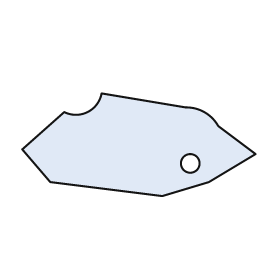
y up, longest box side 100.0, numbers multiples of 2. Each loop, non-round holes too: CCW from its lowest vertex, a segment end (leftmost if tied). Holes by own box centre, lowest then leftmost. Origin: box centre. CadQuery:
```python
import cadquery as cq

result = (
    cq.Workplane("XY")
    .moveTo(10.0, -22.0)
    .lineTo(30.0, -16.0)
    .lineTo(50.0, -4.0)
    .lineTo(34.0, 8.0)
    .threePointArc((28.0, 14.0), (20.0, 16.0))
    .lineTo(-16.0, 22.0)
    .threePointArc((-22.0, 14.0), (-32.0, 14.0))
    .lineTo(-50.0, -2.0)
    .lineTo(-38.0, -16.0)
    .close()
    .moveTo(22.0, -8.0)
    .circle(4.0)
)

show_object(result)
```